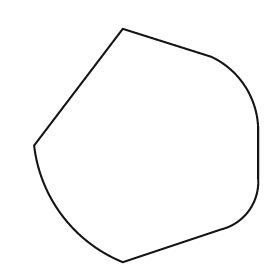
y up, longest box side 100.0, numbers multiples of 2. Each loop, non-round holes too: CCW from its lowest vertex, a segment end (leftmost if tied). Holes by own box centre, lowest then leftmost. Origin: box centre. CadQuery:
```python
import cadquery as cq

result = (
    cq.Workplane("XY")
    .moveTo(-10.0, -50.0)
    .lineTo(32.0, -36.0)
    .threePointArc((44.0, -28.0), (48.0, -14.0))
    .lineTo(48.0, 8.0)
    .threePointArc((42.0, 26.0), (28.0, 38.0))
    .lineTo(-10.0, 50.0)
    .lineTo(-48.0, 0.0)
    .threePointArc((-36.0, -30.0), (-10.0, -50.0))
    .close()
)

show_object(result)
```